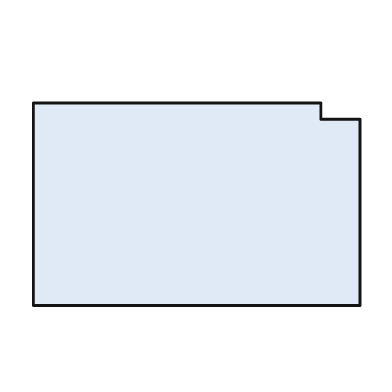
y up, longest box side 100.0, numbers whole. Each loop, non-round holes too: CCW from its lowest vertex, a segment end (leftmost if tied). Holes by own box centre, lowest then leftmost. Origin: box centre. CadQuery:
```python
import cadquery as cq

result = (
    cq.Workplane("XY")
    .moveTo(-50.0, -31.0)
    .lineTo(50.0, -31.0)
    .lineTo(50.0, 26.0)
    .lineTo(38.0, 26.0)
    .lineTo(38.0, 31.0)
    .lineTo(-50.0, 31.0)
    .close()
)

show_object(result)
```